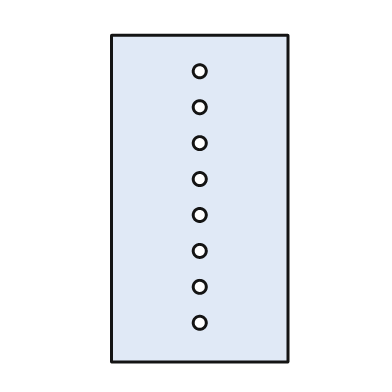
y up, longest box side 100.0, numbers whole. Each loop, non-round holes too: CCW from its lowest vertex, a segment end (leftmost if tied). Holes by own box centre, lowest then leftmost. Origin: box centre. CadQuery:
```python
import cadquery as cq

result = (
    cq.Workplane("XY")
    .moveTo(-27.0, -50.0)
    .lineTo(27.0, -50.0)
    .lineTo(27.0, 50.0)
    .lineTo(-27.0, 50.0)
    .close()
    .moveTo(0.0, -38.0)
    .circle(2.0)
    .moveTo(0.0, -27.0)
    .circle(2.0)
    .moveTo(0.0, -16.0)
    .circle(2.0)
    .moveTo(0.0, -5.0)
    .circle(2.0)
    .moveTo(0.0, 6.0)
    .circle(2.0)
    .moveTo(0.0, 17.0)
    .circle(2.0)
    .moveTo(0.0, 28.0)
    .circle(2.0)
    .moveTo(0.0, 39.0)
    .circle(2.0)
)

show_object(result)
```